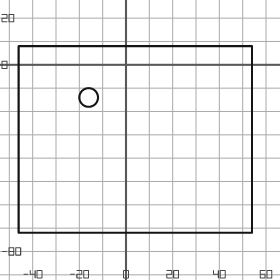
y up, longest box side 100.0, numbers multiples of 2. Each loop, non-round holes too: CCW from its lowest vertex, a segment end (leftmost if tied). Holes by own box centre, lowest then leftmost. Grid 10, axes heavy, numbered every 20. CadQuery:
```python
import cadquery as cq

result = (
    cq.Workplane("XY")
    .moveTo(-46.0, -72.0)
    .lineTo(54.0, -72.0)
    .lineTo(54.0, 8.0)
    .lineTo(-46.0, 8.0)
    .close()
    .moveTo(-16.0, -14.0)
    .circle(4.0)
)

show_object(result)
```